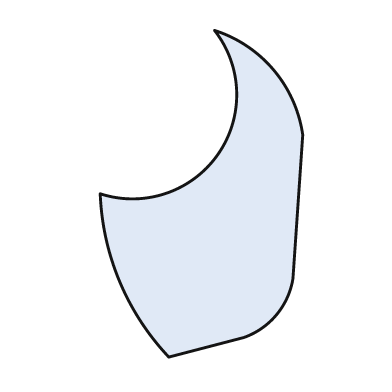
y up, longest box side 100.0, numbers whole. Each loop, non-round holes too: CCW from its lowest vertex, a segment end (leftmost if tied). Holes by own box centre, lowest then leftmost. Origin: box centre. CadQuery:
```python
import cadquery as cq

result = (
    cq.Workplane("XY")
    .moveTo(-10.0, -50.0)
    .lineTo(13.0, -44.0)
    .threePointArc((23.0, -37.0), (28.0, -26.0))
    .lineTo(31.0, 18.0)
    .threePointArc((22.0, 38.0), (4.0, 50.0))
    .threePointArc((5.0, 12.0), (-31.0, 0.0))
    .threePointArc((-25.0, -27.0), (-10.0, -50.0))
    .close()
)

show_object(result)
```